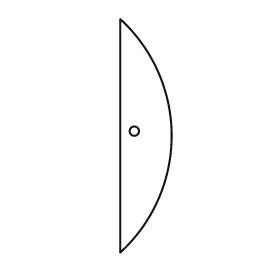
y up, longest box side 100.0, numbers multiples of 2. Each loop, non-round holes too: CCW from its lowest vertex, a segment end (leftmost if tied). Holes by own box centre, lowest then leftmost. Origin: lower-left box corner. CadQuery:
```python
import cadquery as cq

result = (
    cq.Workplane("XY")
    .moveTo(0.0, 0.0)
    .threePointArc((22.0, 50.0), (0.0, 100.0))
    .close()
    .moveTo(6.0, 52.0)
    .circle(2.0)
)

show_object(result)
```